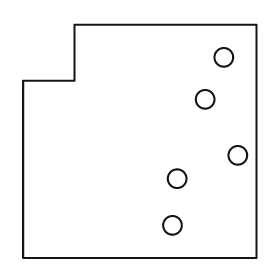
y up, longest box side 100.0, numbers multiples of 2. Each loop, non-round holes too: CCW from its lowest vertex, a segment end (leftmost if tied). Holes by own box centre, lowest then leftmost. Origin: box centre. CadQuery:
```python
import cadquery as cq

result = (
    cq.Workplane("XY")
    .moveTo(-50.0, -50.0)
    .lineTo(50.0, -50.0)
    .lineTo(50.0, 50.0)
    .lineTo(-28.0, 50.0)
    .lineTo(-28.0, 26.0)
    .lineTo(-50.0, 26.0)
    .close()
    .moveTo(14.0, -36.0)
    .circle(4.0)
    .moveTo(16.0, -16.0)
    .circle(4.0)
    .moveTo(42.0, -6.0)
    .circle(4.0)
    .moveTo(28.0, 18.0)
    .circle(4.0)
    .moveTo(36.0, 36.0)
    .circle(4.0)
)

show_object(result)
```